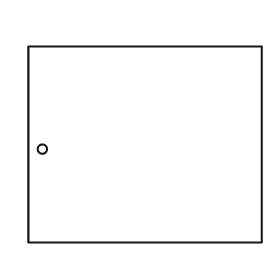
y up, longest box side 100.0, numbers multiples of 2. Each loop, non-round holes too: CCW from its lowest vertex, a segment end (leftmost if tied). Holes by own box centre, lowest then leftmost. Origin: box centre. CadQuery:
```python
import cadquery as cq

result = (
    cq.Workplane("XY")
    .moveTo(-50.0, -42.0)
    .lineTo(50.0, -42.0)
    .lineTo(50.0, 42.0)
    .lineTo(-50.0, 42.0)
    .close()
    .moveTo(-44.0, -2.0)
    .circle(2.0)
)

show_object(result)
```